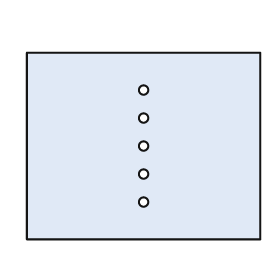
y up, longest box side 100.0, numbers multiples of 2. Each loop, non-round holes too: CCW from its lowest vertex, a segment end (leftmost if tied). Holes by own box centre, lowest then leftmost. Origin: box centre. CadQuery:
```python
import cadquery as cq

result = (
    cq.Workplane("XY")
    .moveTo(-50.0, -40.0)
    .lineTo(50.0, -40.0)
    .lineTo(50.0, 40.0)
    .lineTo(-50.0, 40.0)
    .close()
    .moveTo(0.0, -24.0)
    .circle(2.0)
    .moveTo(0.0, -12.0)
    .circle(2.0)
    .moveTo(0.0, 0.0)
    .circle(2.0)
    .moveTo(0.0, 12.0)
    .circle(2.0)
    .moveTo(0.0, 24.0)
    .circle(2.0)
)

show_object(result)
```